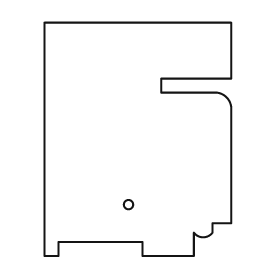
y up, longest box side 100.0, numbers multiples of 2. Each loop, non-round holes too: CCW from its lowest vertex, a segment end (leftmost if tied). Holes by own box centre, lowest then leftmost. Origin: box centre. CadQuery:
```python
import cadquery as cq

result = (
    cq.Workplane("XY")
    .moveTo(-40.0, -50.0)
    .lineTo(-34.0, -50.0)
    .lineTo(-34.0, -44.0)
    .lineTo(2.0, -44.0)
    .lineTo(2.0, -50.0)
    .lineTo(24.0, -50.0)
    .lineTo(24.0, -40.0)
    .threePointArc((28.0, -42.0), (32.0, -40.0))
    .lineTo(32.0, -36.0)
    .lineTo(40.0, -36.0)
    .lineTo(40.0, 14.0)
    .threePointArc((38.0, 18.0), (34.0, 20.0))
    .lineTo(10.0, 20.0)
    .lineTo(10.0, 26.0)
    .lineTo(40.0, 26.0)
    .lineTo(40.0, 50.0)
    .lineTo(-40.0, 50.0)
    .close()
    .moveTo(-4.0, -28.0)
    .circle(2.0)
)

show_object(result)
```